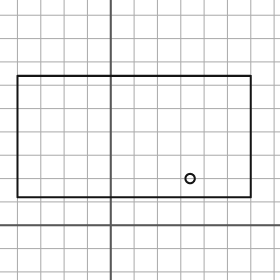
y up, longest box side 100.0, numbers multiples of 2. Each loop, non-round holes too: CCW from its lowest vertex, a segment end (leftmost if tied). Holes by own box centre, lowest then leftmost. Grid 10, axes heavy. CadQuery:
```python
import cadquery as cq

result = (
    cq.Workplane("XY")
    .moveTo(-40.0, 12.0)
    .lineTo(60.0, 12.0)
    .lineTo(60.0, 64.0)
    .lineTo(-40.0, 64.0)
    .close()
    .moveTo(34.0, 20.0)
    .circle(2.0)
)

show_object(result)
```